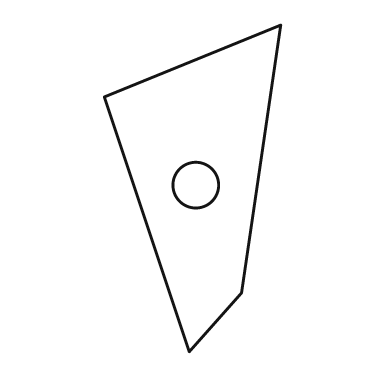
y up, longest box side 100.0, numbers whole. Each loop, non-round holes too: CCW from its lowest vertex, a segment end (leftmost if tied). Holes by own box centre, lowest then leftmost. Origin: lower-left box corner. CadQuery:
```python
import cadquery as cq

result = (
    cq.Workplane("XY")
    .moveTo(26.0, 0.0)
    .lineTo(42.0, 18.0)
    .lineTo(54.0, 100.0)
    .lineTo(0.0, 78.0)
    .close()
    .moveTo(28.0, 51.0)
    .circle(7.0)
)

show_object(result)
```